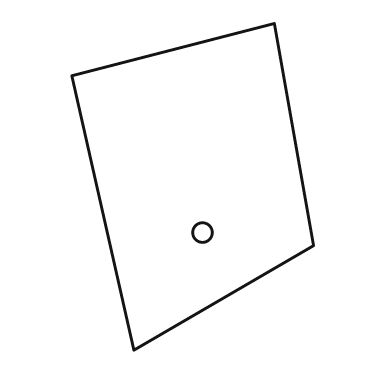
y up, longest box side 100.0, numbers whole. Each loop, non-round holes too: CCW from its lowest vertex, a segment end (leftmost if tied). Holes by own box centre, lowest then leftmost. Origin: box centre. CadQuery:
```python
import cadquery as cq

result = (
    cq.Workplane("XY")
    .moveTo(-18.0, -50.0)
    .lineTo(37.0, -18.0)
    .lineTo(25.0, 50.0)
    .lineTo(-37.0, 34.0)
    .close()
    .moveTo(3.0, -14.0)
    .circle(3.0)
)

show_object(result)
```